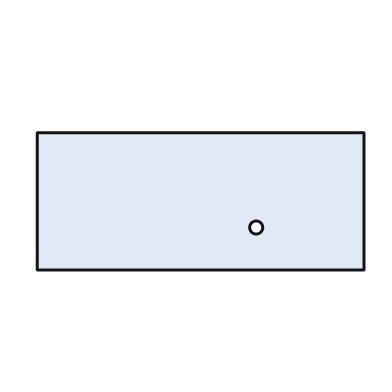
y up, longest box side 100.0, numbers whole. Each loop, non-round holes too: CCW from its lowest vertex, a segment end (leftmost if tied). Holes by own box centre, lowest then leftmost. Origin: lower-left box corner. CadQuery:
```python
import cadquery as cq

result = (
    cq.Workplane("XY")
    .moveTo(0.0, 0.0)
    .lineTo(100.0, 0.0)
    .lineTo(100.0, 42.0)
    .lineTo(0.0, 42.0)
    .close()
    .moveTo(67.0, 13.0)
    .circle(2.0)
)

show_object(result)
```